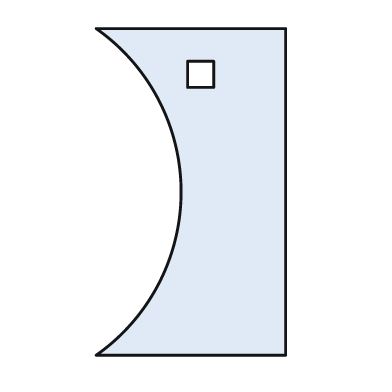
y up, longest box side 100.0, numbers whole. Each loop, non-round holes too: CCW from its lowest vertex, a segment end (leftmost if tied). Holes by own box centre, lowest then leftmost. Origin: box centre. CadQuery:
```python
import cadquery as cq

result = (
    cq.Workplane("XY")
    .moveTo(-29.0, -50.0)
    .lineTo(29.0, -50.0)
    .lineTo(29.0, 50.0)
    .lineTo(-29.0, 50.0)
    .threePointArc((-3.0, 0.0), (-29.0, -50.0))
    .close()
    .moveTo(-1.0, 32.0)
    .lineTo(7.0, 32.0)
    .lineTo(7.0, 40.0)
    .lineTo(-1.0, 40.0)
    .close()
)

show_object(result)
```